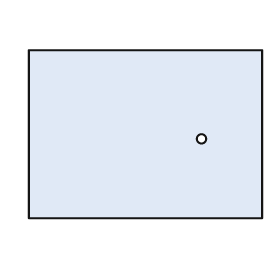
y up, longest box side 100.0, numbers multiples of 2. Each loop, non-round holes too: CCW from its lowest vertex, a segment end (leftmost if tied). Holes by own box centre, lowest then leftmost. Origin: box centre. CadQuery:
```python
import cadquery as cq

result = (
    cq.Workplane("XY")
    .moveTo(-50.0, -36.0)
    .lineTo(50.0, -36.0)
    .lineTo(50.0, 36.0)
    .lineTo(-50.0, 36.0)
    .close()
    .moveTo(24.0, -2.0)
    .circle(2.0)
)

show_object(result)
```